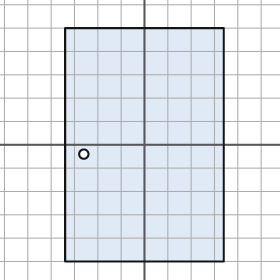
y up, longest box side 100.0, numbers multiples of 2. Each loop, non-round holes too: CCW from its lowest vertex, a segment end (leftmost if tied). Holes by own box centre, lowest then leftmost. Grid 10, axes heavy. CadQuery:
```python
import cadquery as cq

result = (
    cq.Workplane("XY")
    .moveTo(-34.0, -50.0)
    .lineTo(34.0, -50.0)
    .lineTo(34.0, 50.0)
    .lineTo(-34.0, 50.0)
    .close()
    .moveTo(-26.0, -4.0)
    .circle(2.0)
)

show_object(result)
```